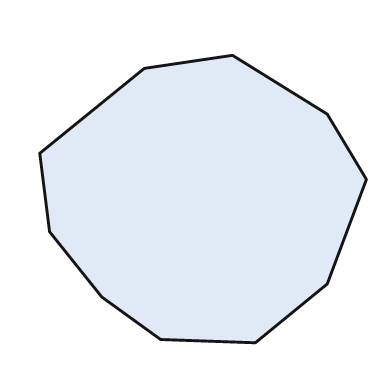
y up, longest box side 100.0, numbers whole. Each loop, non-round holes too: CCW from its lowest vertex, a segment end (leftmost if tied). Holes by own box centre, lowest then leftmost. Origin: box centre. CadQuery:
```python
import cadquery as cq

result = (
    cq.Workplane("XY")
    .moveTo(16.0, -44.0)
    .lineTo(38.0, -26.0)
    .lineTo(50.0, 6.0)
    .lineTo(38.0, 26.0)
    .lineTo(9.0, 44.0)
    .lineTo(-18.0, 40.0)
    .lineTo(-50.0, 14.0)
    .lineTo(-47.0, -10.0)
    .lineTo(-31.0, -30.0)
    .lineTo(-13.0, -43.0)
    .close()
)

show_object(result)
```